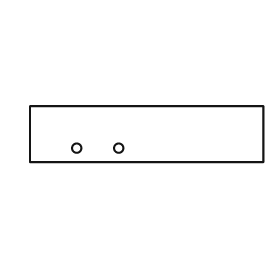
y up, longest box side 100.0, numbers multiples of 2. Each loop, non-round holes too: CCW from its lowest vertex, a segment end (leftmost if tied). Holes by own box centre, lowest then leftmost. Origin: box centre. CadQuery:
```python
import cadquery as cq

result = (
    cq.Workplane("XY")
    .moveTo(-50.0, -12.0)
    .lineTo(50.0, -12.0)
    .lineTo(50.0, 12.0)
    .lineTo(-50.0, 12.0)
    .close()
    .moveTo(-30.0, -6.0)
    .circle(2.0)
    .moveTo(-12.0, -6.0)
    .circle(2.0)
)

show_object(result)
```